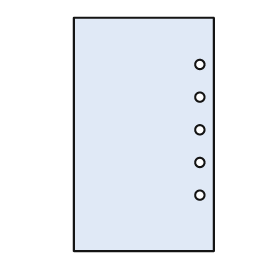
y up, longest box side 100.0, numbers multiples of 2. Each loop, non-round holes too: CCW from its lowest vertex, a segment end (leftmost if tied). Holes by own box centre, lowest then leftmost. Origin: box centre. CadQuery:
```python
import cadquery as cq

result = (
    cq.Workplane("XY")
    .moveTo(-30.0, -50.0)
    .lineTo(30.0, -50.0)
    .lineTo(30.0, 50.0)
    .lineTo(-30.0, 50.0)
    .close()
    .moveTo(24.0, -26.0)
    .circle(2.0)
    .moveTo(24.0, -12.0)
    .circle(2.0)
    .moveTo(24.0, 2.0)
    .circle(2.0)
    .moveTo(24.0, 16.0)
    .circle(2.0)
    .moveTo(24.0, 30.0)
    .circle(2.0)
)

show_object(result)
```